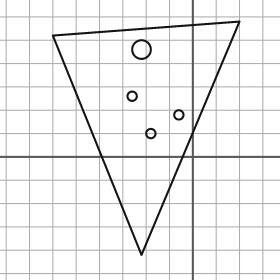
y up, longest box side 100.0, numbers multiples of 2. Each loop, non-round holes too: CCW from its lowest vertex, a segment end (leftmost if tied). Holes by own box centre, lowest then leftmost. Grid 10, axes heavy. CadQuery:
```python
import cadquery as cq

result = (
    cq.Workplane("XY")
    .moveTo(-22.0, -42.0)
    .lineTo(20.0, 58.0)
    .lineTo(-60.0, 52.0)
    .close()
    .moveTo(-18.0, 10.0)
    .circle(2.0)
    .moveTo(-6.0, 18.0)
    .circle(2.0)
    .moveTo(-26.0, 26.0)
    .circle(2.0)
    .moveTo(-22.0, 46.0)
    .circle(4.0)
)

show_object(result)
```